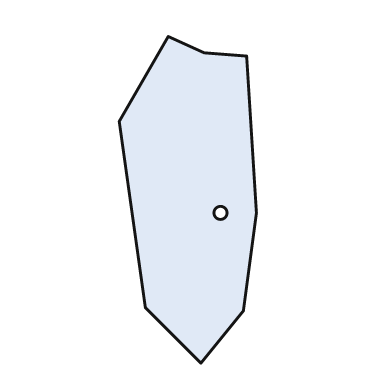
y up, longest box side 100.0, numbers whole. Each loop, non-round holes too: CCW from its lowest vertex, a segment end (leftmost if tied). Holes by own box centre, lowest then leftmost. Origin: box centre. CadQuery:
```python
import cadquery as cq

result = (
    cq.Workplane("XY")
    .moveTo(4.0, -50.0)
    .lineTo(17.0, -34.0)
    .lineTo(21.0, -4.0)
    .lineTo(18.0, 44.0)
    .lineTo(5.0, 45.0)
    .lineTo(-6.0, 50.0)
    .lineTo(-21.0, 24.0)
    .lineTo(-13.0, -33.0)
    .close()
    .moveTo(10.0, -4.0)
    .circle(2.0)
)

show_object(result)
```